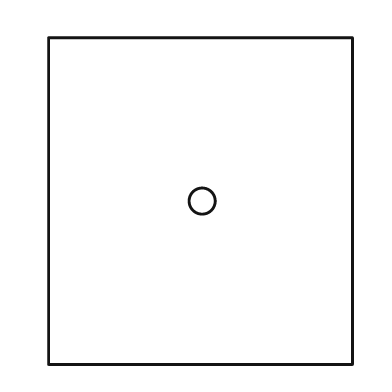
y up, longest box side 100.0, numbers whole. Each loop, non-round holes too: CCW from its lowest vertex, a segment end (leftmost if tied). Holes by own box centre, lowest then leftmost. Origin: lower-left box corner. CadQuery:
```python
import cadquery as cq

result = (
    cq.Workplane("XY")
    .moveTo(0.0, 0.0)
    .lineTo(93.0, 0.0)
    .lineTo(93.0, 100.0)
    .lineTo(0.0, 100.0)
    .close()
    .moveTo(47.0, 50.0)
    .circle(4.0)
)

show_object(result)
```